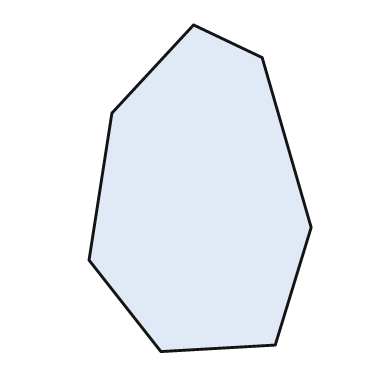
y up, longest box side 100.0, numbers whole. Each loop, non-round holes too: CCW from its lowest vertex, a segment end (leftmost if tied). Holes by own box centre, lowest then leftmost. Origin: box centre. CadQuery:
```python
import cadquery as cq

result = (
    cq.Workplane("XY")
    .moveTo(-12.0, -50.0)
    .lineTo(23.0, -48.0)
    .lineTo(34.0, -12.0)
    .lineTo(19.0, 40.0)
    .lineTo(-2.0, 50.0)
    .lineTo(-27.0, 23.0)
    .lineTo(-34.0, -22.0)
    .close()
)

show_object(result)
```